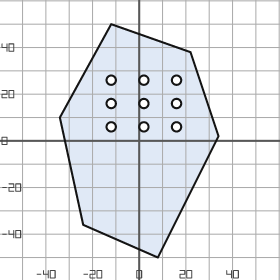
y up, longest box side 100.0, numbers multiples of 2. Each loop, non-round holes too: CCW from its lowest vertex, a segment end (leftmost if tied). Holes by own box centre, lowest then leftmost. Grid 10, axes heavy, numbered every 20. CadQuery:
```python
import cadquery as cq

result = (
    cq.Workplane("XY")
    .moveTo(8.0, -50.0)
    .lineTo(34.0, 2.0)
    .lineTo(22.0, 38.0)
    .lineTo(-12.0, 50.0)
    .lineTo(-34.0, 10.0)
    .lineTo(-24.0, -36.0)
    .close()
    .moveTo(-12.0, 6.0)
    .circle(2.0)
    .moveTo(2.0, 6.0)
    .circle(2.0)
    .moveTo(16.0, 6.0)
    .circle(2.0)
    .moveTo(-12.0, 16.0)
    .circle(2.0)
    .moveTo(2.0, 16.0)
    .circle(2.0)
    .moveTo(16.0, 16.0)
    .circle(2.0)
    .moveTo(-12.0, 26.0)
    .circle(2.0)
    .moveTo(2.0, 26.0)
    .circle(2.0)
    .moveTo(16.0, 26.0)
    .circle(2.0)
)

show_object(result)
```